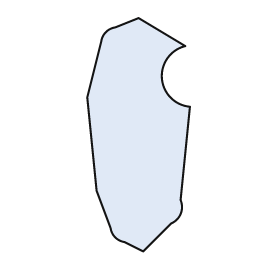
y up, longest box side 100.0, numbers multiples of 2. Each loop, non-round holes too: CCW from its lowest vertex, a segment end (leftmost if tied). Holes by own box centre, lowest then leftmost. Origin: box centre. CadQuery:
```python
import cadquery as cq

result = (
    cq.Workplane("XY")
    .moveTo(2.0, -50.0)
    .lineTo(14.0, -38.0)
    .threePointArc((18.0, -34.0), (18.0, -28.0))
    .lineTo(22.0, 12.0)
    .threePointArc((10.0, 24.0), (20.0, 38.0))
    .lineTo(0.0, 50.0)
    .lineTo(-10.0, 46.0)
    .threePointArc((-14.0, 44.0), (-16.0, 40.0))
    .lineTo(-22.0, 16.0)
    .lineTo(-18.0, -24.0)
    .lineTo(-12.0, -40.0)
    .threePointArc((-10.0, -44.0), (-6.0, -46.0))
    .close()
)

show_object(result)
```